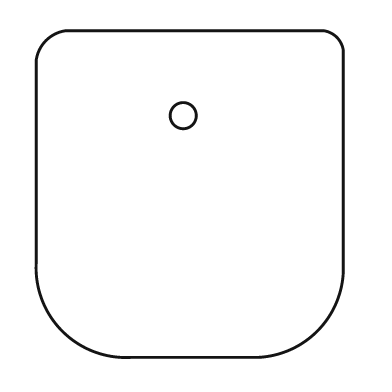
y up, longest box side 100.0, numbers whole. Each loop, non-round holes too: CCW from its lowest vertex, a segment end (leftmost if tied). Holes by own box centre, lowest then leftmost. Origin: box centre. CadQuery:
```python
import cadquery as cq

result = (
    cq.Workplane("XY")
    .moveTo(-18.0, -50.0)
    .lineTo(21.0, -50.0)
    .threePointArc((39.0, -42.0), (47.0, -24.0))
    .lineTo(47.0, 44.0)
    .threePointArc((45.0, 48.0), (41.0, 50.0))
    .lineTo(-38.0, 50.0)
    .threePointArc((-44.0, 47.0), (-47.0, 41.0))
    .lineTo(-47.0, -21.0)
    .threePointArc((-39.0, -42.0), (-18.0, -50.0))
    .close()
    .moveTo(-2.0, 24.0)
    .circle(4.0)
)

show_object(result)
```